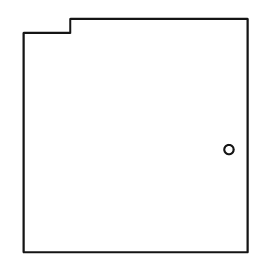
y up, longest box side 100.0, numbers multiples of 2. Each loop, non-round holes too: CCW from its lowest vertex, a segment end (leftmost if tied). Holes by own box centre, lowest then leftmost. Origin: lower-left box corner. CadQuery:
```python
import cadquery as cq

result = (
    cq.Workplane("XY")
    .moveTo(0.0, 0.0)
    .lineTo(96.0, 0.0)
    .lineTo(96.0, 100.0)
    .lineTo(20.0, 100.0)
    .lineTo(20.0, 94.0)
    .lineTo(0.0, 94.0)
    .close()
    .moveTo(88.0, 44.0)
    .circle(2.0)
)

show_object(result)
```